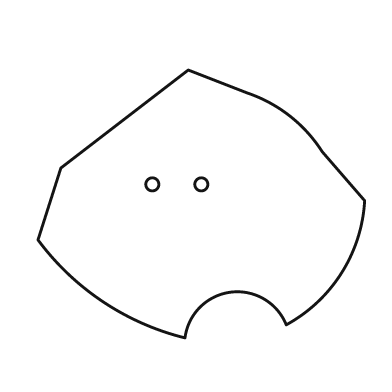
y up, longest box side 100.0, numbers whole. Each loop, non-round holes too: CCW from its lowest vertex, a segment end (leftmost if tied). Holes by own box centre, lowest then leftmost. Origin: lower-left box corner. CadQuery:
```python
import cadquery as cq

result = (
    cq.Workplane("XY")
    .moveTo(45.0, 0.0)
    .threePointArc((59.0, 14.0), (76.0, 4.0))
    .threePointArc((93.0, 20.0), (100.0, 42.0))
    .lineTo(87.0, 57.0)
    .threePointArc((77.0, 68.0), (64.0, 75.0))
    .lineTo(46.0, 82.0)
    .lineTo(7.0, 52.0)
    .lineTo(0.0, 30.0)
    .threePointArc((20.0, 11.0), (45.0, 0.0))
    .close()
    .moveTo(35.0, 47.0)
    .circle(2.0)
    .moveTo(50.0, 47.0)
    .circle(2.0)
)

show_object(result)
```